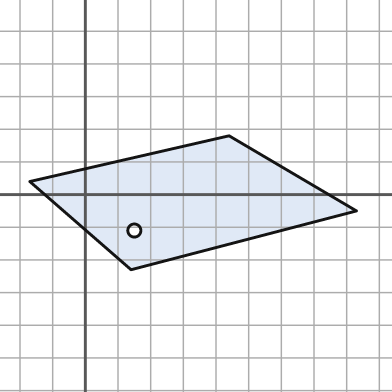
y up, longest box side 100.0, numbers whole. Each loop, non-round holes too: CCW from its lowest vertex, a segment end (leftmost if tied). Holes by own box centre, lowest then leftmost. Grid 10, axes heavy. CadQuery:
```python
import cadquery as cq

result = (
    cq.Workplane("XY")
    .moveTo(14.0, -23.0)
    .lineTo(83.0, -5.0)
    .lineTo(44.0, 18.0)
    .lineTo(-17.0, 4.0)
    .close()
    .moveTo(15.0, -11.0)
    .circle(2.0)
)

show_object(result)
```